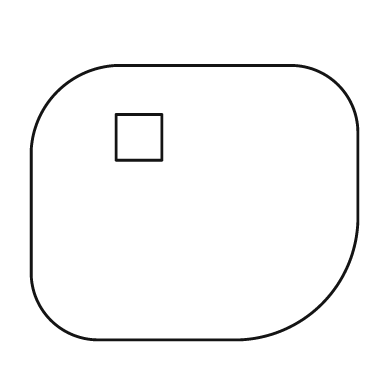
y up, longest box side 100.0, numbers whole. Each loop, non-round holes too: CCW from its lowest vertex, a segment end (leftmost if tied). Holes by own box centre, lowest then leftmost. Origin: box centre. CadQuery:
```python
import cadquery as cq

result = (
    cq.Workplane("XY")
    .moveTo(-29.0, -42.0)
    .lineTo(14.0, -42.0)
    .threePointArc((39.0, -31.0), (50.0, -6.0))
    .lineTo(50.0, 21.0)
    .threePointArc((44.0, 36.0), (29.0, 42.0))
    .lineTo(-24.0, 42.0)
    .threePointArc((-42.0, 34.0), (-50.0, 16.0))
    .lineTo(-50.0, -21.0)
    .threePointArc((-44.0, -36.0), (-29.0, -42.0))
    .close()
    .moveTo(-24.0, 13.0)
    .lineTo(-10.0, 13.0)
    .lineTo(-10.0, 27.0)
    .lineTo(-24.0, 27.0)
    .close()
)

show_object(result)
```